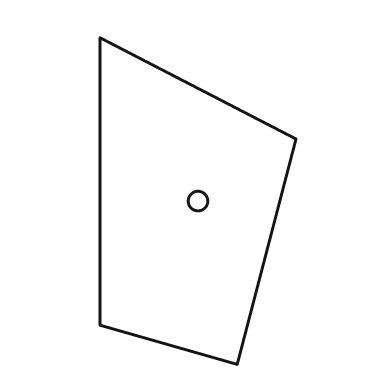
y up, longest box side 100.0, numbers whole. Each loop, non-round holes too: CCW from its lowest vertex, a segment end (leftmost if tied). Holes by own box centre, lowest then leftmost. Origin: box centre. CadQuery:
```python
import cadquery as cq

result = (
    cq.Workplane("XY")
    .moveTo(12.0, -50.0)
    .lineTo(30.0, 19.0)
    .lineTo(-30.0, 50.0)
    .lineTo(-30.0, -38.0)
    .close()
    .moveTo(0.0, 0.0)
    .circle(3.0)
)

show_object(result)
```